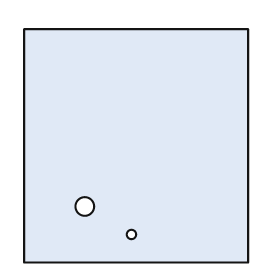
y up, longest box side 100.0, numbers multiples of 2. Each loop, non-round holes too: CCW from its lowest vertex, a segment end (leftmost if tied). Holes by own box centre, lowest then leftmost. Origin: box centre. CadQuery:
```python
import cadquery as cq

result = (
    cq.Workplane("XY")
    .moveTo(-48.0, -50.0)
    .lineTo(48.0, -50.0)
    .lineTo(48.0, 50.0)
    .lineTo(-48.0, 50.0)
    .close()
    .moveTo(-2.0, -38.0)
    .circle(2.0)
    .moveTo(-22.0, -26.0)
    .circle(4.0)
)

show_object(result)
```